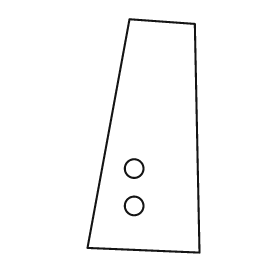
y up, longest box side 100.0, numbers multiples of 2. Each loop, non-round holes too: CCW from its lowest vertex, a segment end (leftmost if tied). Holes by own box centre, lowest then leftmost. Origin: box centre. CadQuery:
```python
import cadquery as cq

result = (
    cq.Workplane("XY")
    .moveTo(24.0, -50.0)
    .lineTo(22.0, 48.0)
    .lineTo(-6.0, 50.0)
    .lineTo(-24.0, -48.0)
    .close()
    .moveTo(-4.0, -30.0)
    .circle(4.0)
    .moveTo(-4.0, -14.0)
    .circle(4.0)
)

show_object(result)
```